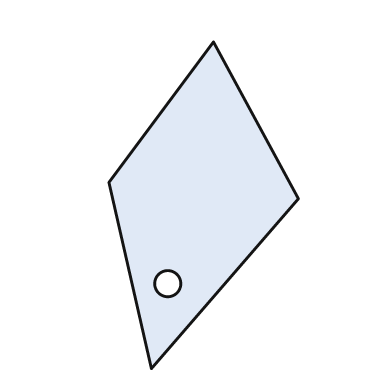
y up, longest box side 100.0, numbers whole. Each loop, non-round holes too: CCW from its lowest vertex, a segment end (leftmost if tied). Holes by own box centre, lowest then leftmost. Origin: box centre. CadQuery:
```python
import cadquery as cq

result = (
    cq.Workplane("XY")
    .moveTo(-16.0, -50.0)
    .lineTo(29.0, 2.0)
    .lineTo(3.0, 50.0)
    .lineTo(-29.0, 7.0)
    .close()
    .moveTo(-11.0, -24.0)
    .circle(4.0)
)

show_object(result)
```